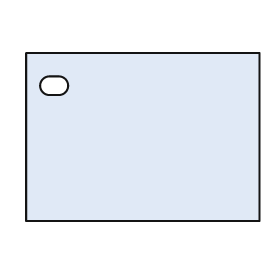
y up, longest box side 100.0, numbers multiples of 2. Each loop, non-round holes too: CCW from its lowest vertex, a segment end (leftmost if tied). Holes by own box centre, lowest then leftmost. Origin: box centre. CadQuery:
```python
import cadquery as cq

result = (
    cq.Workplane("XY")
    .moveTo(-50.0, -36.0)
    .lineTo(50.0, -36.0)
    .lineTo(50.0, 36.0)
    .lineTo(-50.0, 36.0)
    .close()
    .moveTo(-40.0, 18.0)
    .lineTo(-36.0, 18.0)
    .threePointArc((-32.0, 22.0), (-36.0, 26.0))
    .lineTo(-40.0, 26.0)
    .threePointArc((-44.0, 22.0), (-40.0, 18.0))
    .close()
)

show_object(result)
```